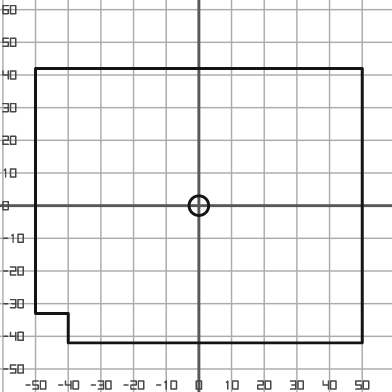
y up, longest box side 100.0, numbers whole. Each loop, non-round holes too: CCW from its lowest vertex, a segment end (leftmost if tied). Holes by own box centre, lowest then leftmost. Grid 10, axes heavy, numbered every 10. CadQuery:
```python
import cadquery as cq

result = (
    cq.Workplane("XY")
    .moveTo(-40.0, -42.0)
    .lineTo(50.0, -42.0)
    .lineTo(50.0, 42.0)
    .lineTo(-50.0, 42.0)
    .lineTo(-50.0, -33.0)
    .lineTo(-40.0, -33.0)
    .close()
    .moveTo(0.0, 0.0)
    .circle(3.0)
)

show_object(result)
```